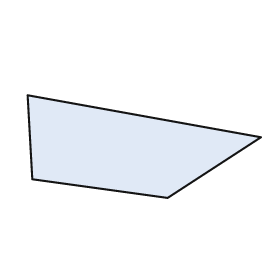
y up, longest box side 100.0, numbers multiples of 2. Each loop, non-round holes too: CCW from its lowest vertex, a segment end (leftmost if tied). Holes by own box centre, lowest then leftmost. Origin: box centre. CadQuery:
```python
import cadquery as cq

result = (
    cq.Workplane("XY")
    .moveTo(10.0, -22.0)
    .lineTo(50.0, 4.0)
    .lineTo(-50.0, 22.0)
    .lineTo(-48.0, -14.0)
    .close()
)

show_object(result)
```